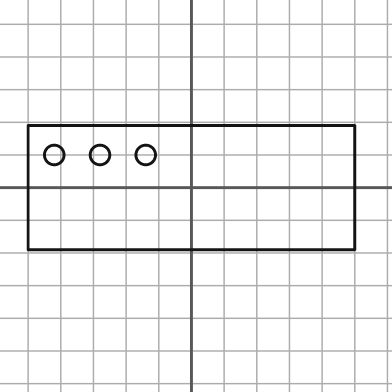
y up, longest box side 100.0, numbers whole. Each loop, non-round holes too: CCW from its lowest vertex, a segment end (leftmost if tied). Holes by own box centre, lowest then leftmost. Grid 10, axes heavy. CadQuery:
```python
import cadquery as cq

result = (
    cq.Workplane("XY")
    .moveTo(-50.0, -19.0)
    .lineTo(50.0, -19.0)
    .lineTo(50.0, 19.0)
    .lineTo(-50.0, 19.0)
    .close()
    .moveTo(-42.0, 10.0)
    .circle(3.0)
    .moveTo(-28.0, 10.0)
    .circle(3.0)
    .moveTo(-14.0, 10.0)
    .circle(3.0)
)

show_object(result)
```